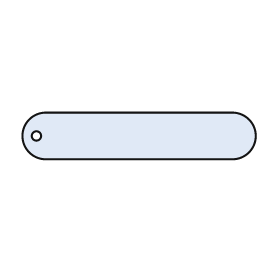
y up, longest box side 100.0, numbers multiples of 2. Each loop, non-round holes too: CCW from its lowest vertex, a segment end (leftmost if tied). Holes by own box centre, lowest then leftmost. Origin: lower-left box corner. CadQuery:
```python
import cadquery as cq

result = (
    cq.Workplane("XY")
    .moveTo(10.0, 0.0)
    .lineTo(90.0, 0.0)
    .threePointArc((100.0, 10.0), (90.0, 20.0))
    .lineTo(10.0, 20.0)
    .threePointArc((0.0, 10.0), (10.0, 0.0))
    .close()
    .moveTo(6.0, 10.0)
    .circle(2.0)
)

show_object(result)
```